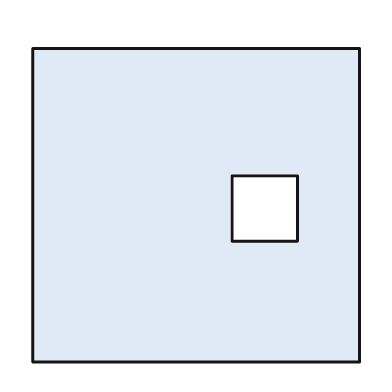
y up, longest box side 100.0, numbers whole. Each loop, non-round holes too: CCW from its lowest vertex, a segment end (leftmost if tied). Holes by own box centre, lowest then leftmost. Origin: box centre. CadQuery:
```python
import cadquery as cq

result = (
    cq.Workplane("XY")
    .moveTo(-50.0, -48.0)
    .lineTo(50.0, -48.0)
    .lineTo(50.0, 48.0)
    .lineTo(-50.0, 48.0)
    .close()
    .moveTo(11.0, -11.0)
    .lineTo(31.0, -11.0)
    .lineTo(31.0, 9.0)
    .lineTo(11.0, 9.0)
    .close()
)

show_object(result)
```